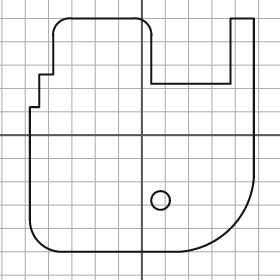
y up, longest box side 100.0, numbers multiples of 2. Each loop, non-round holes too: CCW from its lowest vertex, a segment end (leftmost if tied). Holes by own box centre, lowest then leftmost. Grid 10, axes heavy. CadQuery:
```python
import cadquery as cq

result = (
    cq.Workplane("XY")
    .moveTo(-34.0, -50.0)
    .lineTo(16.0, -50.0)
    .threePointArc((38.0, -40.0), (48.0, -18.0))
    .lineTo(48.0, 50.0)
    .lineTo(38.0, 50.0)
    .lineTo(38.0, 22.0)
    .lineTo(4.0, 22.0)
    .lineTo(4.0, 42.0)
    .threePointArc((2.0, 48.0), (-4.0, 50.0))
    .lineTo(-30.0, 50.0)
    .threePointArc((-36.0, 48.0), (-38.0, 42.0))
    .lineTo(-38.0, 26.0)
    .lineTo(-44.0, 26.0)
    .lineTo(-44.0, 12.0)
    .lineTo(-48.0, 12.0)
    .lineTo(-48.0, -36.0)
    .threePointArc((-44.0, -46.0), (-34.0, -50.0))
    .close()
    .moveTo(8.0, -28.0)
    .circle(4.0)
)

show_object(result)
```